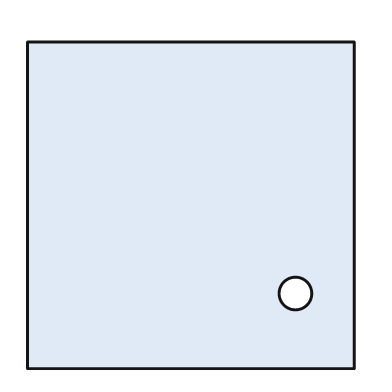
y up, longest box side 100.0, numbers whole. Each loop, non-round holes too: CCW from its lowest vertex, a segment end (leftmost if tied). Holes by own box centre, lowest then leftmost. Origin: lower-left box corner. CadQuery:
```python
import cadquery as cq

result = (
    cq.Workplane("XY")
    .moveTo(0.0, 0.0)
    .lineTo(100.0, 0.0)
    .lineTo(100.0, 100.0)
    .lineTo(0.0, 100.0)
    .close()
    .moveTo(82.0, 23.0)
    .circle(5.0)
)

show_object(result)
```